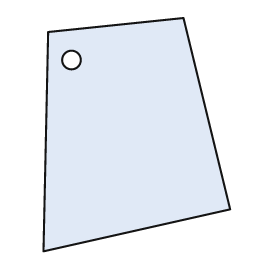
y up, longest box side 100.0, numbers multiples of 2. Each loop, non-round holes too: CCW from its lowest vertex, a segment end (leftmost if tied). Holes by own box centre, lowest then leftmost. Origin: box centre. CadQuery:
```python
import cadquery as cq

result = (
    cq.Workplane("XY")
    .moveTo(-40.0, -50.0)
    .lineTo(40.0, -32.0)
    .lineTo(20.0, 50.0)
    .lineTo(-38.0, 44.0)
    .close()
    .moveTo(-28.0, 32.0)
    .circle(4.0)
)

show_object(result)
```